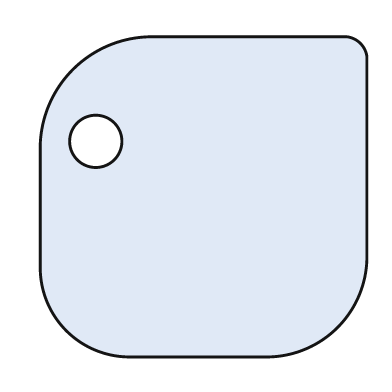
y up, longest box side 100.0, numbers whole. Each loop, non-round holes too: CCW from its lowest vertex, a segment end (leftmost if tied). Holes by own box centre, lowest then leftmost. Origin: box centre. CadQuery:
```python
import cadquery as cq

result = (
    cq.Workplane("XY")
    .moveTo(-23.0, -49.0)
    .lineTo(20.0, -49.0)
    .threePointArc((41.0, -40.0), (50.0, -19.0))
    .lineTo(50.0, 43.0)
    .threePointArc((48.0, 47.0), (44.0, 49.0))
    .lineTo(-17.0, 49.0)
    .threePointArc((-40.0, 39.0), (-50.0, 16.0))
    .lineTo(-50.0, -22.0)
    .threePointArc((-42.0, -41.0), (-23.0, -49.0))
    .close()
    .moveTo(-33.0, 17.0)
    .circle(8.0)
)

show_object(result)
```